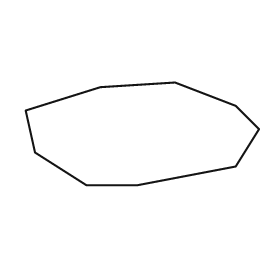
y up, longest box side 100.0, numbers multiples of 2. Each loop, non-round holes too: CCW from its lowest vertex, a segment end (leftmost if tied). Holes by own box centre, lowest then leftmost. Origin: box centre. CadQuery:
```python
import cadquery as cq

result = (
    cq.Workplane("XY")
    .moveTo(-24.0, -22.0)
    .lineTo(-2.0, -22.0)
    .lineTo(40.0, -14.0)
    .lineTo(50.0, 2.0)
    .lineTo(40.0, 12.0)
    .lineTo(14.0, 22.0)
    .lineTo(-18.0, 20.0)
    .lineTo(-50.0, 10.0)
    .lineTo(-46.0, -8.0)
    .close()
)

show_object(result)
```